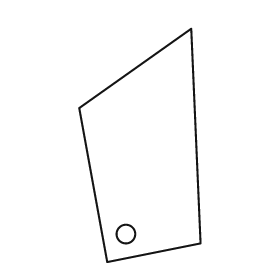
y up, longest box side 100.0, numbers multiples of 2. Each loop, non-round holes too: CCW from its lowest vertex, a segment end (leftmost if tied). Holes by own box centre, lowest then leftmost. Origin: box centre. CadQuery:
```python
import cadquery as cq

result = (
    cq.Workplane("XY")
    .moveTo(-14.0, -50.0)
    .lineTo(26.0, -42.0)
    .lineTo(22.0, 50.0)
    .lineTo(-26.0, 16.0)
    .close()
    .moveTo(-6.0, -38.0)
    .circle(4.0)
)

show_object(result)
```